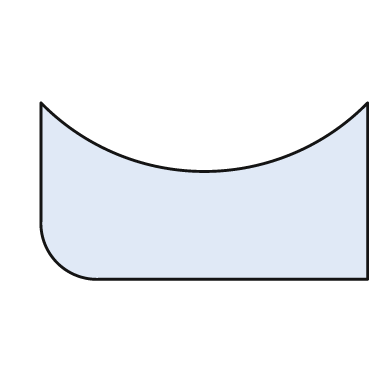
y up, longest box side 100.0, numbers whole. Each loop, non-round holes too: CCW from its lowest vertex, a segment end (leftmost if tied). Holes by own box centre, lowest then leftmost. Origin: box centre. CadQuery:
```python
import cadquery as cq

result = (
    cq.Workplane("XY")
    .moveTo(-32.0, -27.0)
    .lineTo(50.0, -27.0)
    .lineTo(50.0, 27.0)
    .threePointArc((0.0, 6.0), (-50.0, 27.0))
    .lineTo(-50.0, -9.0)
    .threePointArc((-45.0, -22.0), (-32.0, -27.0))
    .close()
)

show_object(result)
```